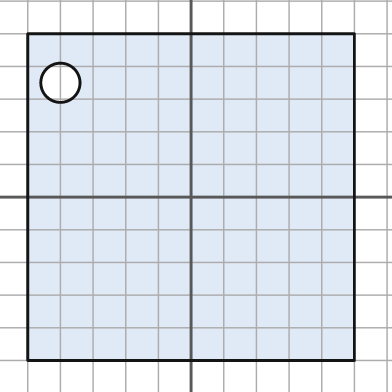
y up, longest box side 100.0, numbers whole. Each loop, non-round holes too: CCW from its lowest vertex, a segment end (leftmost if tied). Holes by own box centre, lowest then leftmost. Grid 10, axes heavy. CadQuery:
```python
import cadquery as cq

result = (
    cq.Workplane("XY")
    .moveTo(-50.0, -50.0)
    .lineTo(50.0, -50.0)
    .lineTo(50.0, 50.0)
    .lineTo(-50.0, 50.0)
    .close()
    .moveTo(-40.0, 35.0)
    .circle(6.0)
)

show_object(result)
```